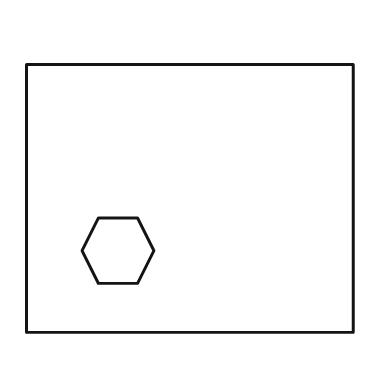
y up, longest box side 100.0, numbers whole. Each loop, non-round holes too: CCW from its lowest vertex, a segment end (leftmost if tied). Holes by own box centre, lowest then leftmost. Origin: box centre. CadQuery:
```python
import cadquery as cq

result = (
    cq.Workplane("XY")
    .moveTo(-50.0, -41.0)
    .lineTo(50.0, -41.0)
    .lineTo(50.0, 41.0)
    .lineTo(-50.0, 41.0)
    .close()
    .moveTo(-28.0, -26.0)
    .lineTo(-16.0, -26.0)
    .lineTo(-11.0, -16.0)
    .lineTo(-16.0, -6.0)
    .lineTo(-28.0, -6.0)
    .lineTo(-33.0, -16.0)
    .close()
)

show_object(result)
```